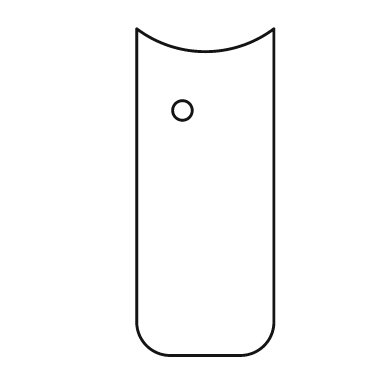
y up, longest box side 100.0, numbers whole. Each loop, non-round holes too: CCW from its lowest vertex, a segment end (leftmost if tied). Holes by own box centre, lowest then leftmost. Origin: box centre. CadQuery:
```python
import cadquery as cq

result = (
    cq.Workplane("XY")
    .moveTo(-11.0, -50.0)
    .lineTo(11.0, -50.0)
    .threePointArc((18.0, -47.0), (21.0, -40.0))
    .lineTo(21.0, 50.0)
    .threePointArc((0.0, 43.0), (-21.0, 50.0))
    .lineTo(-21.0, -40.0)
    .threePointArc((-18.0, -47.0), (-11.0, -50.0))
    .close()
    .moveTo(-7.0, 25.0)
    .circle(3.0)
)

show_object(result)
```